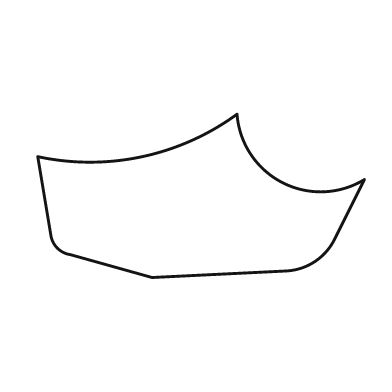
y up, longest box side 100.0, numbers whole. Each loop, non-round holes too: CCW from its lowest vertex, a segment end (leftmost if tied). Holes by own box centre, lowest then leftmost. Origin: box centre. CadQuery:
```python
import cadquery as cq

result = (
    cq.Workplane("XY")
    .moveTo(-15.0, -25.0)
    .lineTo(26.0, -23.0)
    .threePointArc((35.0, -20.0), (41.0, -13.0))
    .lineTo(50.0, 5.0)
    .threePointArc((25.0, 4.0), (11.0, 25.0))
    .threePointArc((-18.0, 12.0), (-50.0, 12.0))
    .lineTo(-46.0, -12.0)
    .threePointArc((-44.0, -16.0), (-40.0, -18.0))
    .close()
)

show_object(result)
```